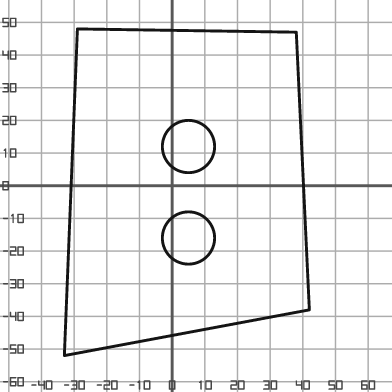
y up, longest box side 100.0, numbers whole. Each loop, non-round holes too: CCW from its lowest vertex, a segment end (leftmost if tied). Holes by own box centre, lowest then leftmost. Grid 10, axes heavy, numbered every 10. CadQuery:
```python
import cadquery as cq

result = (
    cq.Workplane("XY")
    .moveTo(-33.0, -52.0)
    .lineTo(42.0, -38.0)
    .lineTo(38.0, 47.0)
    .lineTo(-29.0, 48.0)
    .close()
    .moveTo(5.0, -16.0)
    .circle(8.0)
    .moveTo(5.0, 12.0)
    .circle(8.0)
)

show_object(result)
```